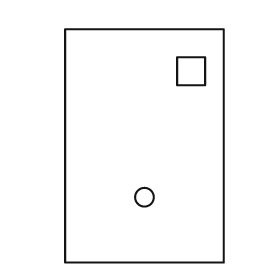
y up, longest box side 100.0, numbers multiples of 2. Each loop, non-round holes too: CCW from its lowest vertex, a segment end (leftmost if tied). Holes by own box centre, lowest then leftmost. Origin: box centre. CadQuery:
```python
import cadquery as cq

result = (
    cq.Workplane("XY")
    .moveTo(-34.0, -50.0)
    .lineTo(34.0, -50.0)
    .lineTo(34.0, 50.0)
    .lineTo(-34.0, 50.0)
    .close()
    .moveTo(0.0, -22.0)
    .circle(4.0)
    .moveTo(14.0, 26.0)
    .lineTo(26.0, 26.0)
    .lineTo(26.0, 38.0)
    .lineTo(14.0, 38.0)
    .close()
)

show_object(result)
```